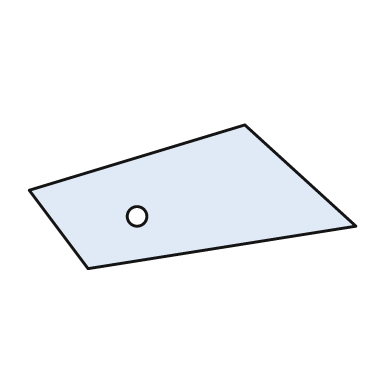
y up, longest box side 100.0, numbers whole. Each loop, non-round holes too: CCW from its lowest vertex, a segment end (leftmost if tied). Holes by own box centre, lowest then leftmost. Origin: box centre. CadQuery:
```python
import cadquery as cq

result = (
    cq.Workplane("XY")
    .moveTo(-32.0, -22.0)
    .lineTo(50.0, -9.0)
    .lineTo(16.0, 22.0)
    .lineTo(-50.0, 2.0)
    .close()
    .moveTo(-17.0, -6.0)
    .circle(3.0)
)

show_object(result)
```